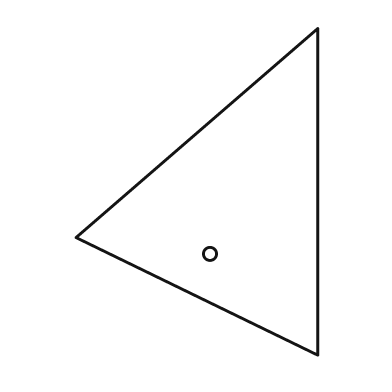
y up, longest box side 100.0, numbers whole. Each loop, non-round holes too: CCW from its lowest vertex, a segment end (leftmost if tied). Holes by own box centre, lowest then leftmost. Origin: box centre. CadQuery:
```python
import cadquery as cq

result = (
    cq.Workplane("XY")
    .moveTo(37.0, -50.0)
    .lineTo(37.0, 50.0)
    .lineTo(-37.0, -14.0)
    .close()
    .moveTo(4.0, -19.0)
    .circle(2.0)
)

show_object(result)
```